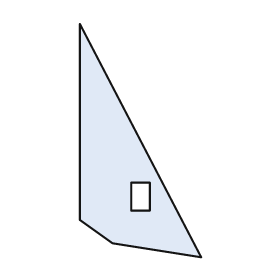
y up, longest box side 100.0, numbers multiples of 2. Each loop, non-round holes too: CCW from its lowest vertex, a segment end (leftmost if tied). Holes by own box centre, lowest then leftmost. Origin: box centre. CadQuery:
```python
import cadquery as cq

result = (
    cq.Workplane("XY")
    .moveTo(26.0, -50.0)
    .lineTo(-26.0, 50.0)
    .lineTo(-26.0, -34.0)
    .lineTo(-12.0, -44.0)
    .close()
    .moveTo(-4.0, -30.0)
    .lineTo(4.0, -30.0)
    .lineTo(4.0, -18.0)
    .lineTo(-4.0, -18.0)
    .close()
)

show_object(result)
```